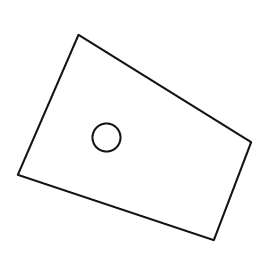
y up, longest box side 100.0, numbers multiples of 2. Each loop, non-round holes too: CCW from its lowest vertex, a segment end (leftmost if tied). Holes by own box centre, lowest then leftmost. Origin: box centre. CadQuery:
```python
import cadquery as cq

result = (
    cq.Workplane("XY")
    .moveTo(34.0, -44.0)
    .lineTo(50.0, -2.0)
    .lineTo(-24.0, 44.0)
    .lineTo(-50.0, -16.0)
    .close()
    .moveTo(-12.0, 0.0)
    .circle(6.0)
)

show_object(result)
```